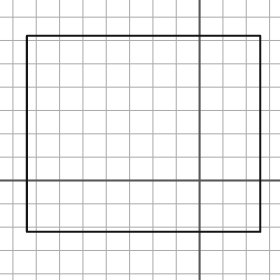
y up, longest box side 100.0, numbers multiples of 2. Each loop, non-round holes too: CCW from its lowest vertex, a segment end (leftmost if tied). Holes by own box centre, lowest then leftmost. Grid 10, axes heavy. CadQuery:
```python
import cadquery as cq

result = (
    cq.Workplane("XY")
    .moveTo(-74.0, -22.0)
    .lineTo(26.0, -22.0)
    .lineTo(26.0, 62.0)
    .lineTo(-74.0, 62.0)
    .close()
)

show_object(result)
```